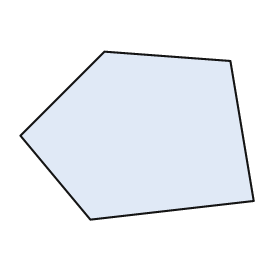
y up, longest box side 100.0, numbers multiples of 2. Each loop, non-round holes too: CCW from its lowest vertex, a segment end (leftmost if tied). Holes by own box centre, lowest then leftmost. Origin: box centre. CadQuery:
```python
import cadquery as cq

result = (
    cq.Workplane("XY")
    .moveTo(-20.0, -36.0)
    .lineTo(50.0, -28.0)
    .lineTo(40.0, 32.0)
    .lineTo(-14.0, 36.0)
    .lineTo(-50.0, 0.0)
    .close()
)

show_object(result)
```